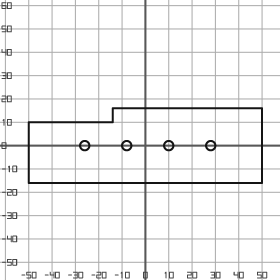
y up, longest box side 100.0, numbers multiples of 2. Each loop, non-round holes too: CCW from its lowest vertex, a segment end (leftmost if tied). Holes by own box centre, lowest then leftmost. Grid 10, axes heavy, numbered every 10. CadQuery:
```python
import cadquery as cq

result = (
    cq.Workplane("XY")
    .moveTo(-50.0, -16.0)
    .lineTo(50.0, -16.0)
    .lineTo(50.0, 16.0)
    .lineTo(-14.0, 16.0)
    .lineTo(-14.0, 10.0)
    .lineTo(-50.0, 10.0)
    .close()
    .moveTo(-26.0, 0.0)
    .circle(2.0)
    .moveTo(-8.0, 0.0)
    .circle(2.0)
    .moveTo(10.0, 0.0)
    .circle(2.0)
    .moveTo(28.0, 0.0)
    .circle(2.0)
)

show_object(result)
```